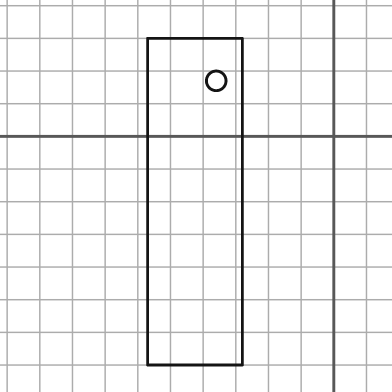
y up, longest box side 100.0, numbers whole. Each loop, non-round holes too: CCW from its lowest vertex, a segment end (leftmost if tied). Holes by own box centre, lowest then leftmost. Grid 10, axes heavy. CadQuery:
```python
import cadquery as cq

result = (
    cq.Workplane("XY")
    .moveTo(-57.0, -70.0)
    .lineTo(-28.0, -70.0)
    .lineTo(-28.0, 30.0)
    .lineTo(-57.0, 30.0)
    .close()
    .moveTo(-36.0, 17.0)
    .circle(3.0)
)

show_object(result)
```